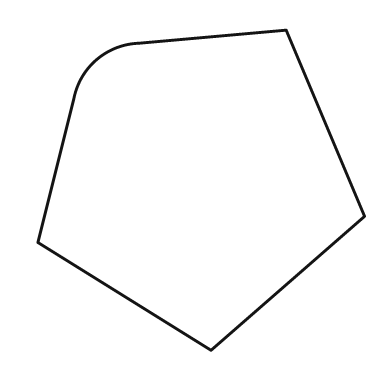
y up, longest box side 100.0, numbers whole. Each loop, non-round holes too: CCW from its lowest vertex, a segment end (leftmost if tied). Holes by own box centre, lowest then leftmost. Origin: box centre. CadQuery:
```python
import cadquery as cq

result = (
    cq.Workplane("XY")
    .moveTo(3.0, -49.0)
    .lineTo(50.0, -8.0)
    .lineTo(26.0, 49.0)
    .lineTo(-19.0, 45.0)
    .threePointArc((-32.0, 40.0), (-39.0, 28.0))
    .lineTo(-50.0, -16.0)
    .close()
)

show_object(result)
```